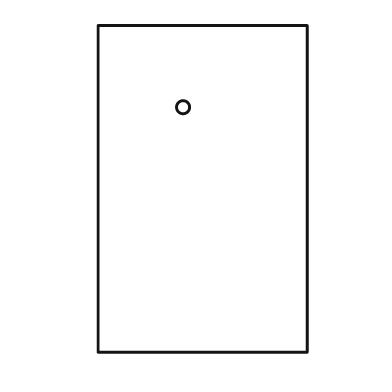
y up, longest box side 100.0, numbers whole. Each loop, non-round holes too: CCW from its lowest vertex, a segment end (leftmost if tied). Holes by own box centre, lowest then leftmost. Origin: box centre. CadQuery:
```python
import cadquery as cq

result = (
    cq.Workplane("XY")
    .moveTo(-32.0, -50.0)
    .lineTo(32.0, -50.0)
    .lineTo(32.0, 50.0)
    .lineTo(-32.0, 50.0)
    .close()
    .moveTo(-6.0, 25.0)
    .circle(2.0)
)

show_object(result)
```